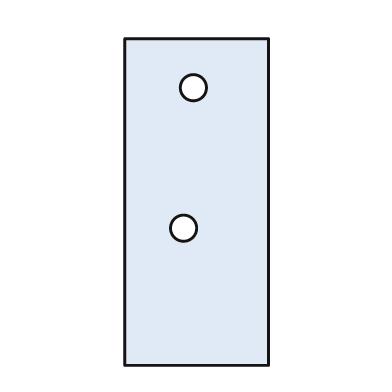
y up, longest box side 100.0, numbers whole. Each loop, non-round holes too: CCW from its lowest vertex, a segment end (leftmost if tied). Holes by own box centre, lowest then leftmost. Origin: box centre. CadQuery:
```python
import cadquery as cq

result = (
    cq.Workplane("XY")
    .moveTo(-22.0, -50.0)
    .lineTo(22.0, -50.0)
    .lineTo(22.0, 50.0)
    .lineTo(-22.0, 50.0)
    .close()
    .moveTo(-4.0, -8.0)
    .circle(4.0)
    .moveTo(-1.0, 35.0)
    .circle(4.0)
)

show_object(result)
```